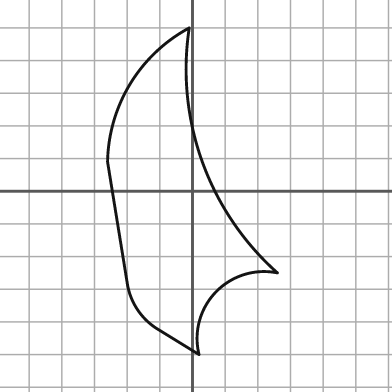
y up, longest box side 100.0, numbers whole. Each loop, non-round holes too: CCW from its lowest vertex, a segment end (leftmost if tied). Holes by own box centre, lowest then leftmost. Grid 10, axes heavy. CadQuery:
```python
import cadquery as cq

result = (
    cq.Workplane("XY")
    .moveTo(2.0, -50.0)
    .threePointArc((7.0, -31.0), (26.0, -25.0))
    .threePointArc((3.0, 9.0), (-1.0, 50.0))
    .threePointArc((-19.0, 33.0), (-26.0, 9.0))
    .lineTo(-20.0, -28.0)
    .threePointArc((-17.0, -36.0), (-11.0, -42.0))
    .close()
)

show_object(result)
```